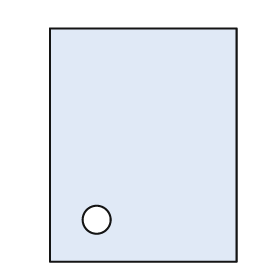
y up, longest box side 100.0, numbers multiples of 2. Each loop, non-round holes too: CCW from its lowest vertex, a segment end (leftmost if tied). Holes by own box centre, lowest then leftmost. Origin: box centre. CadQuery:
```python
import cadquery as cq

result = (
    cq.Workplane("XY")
    .moveTo(-40.0, -50.0)
    .lineTo(40.0, -50.0)
    .lineTo(40.0, 50.0)
    .lineTo(-40.0, 50.0)
    .close()
    .moveTo(-20.0, -32.0)
    .circle(6.0)
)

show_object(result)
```